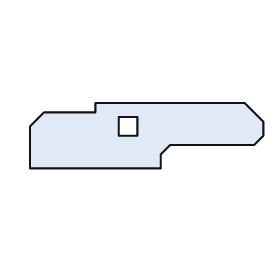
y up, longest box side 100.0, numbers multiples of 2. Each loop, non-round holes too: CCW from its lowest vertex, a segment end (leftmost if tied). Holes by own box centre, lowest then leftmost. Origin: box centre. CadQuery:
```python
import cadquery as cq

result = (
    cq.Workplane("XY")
    .moveTo(-50.0, -14.0)
    .lineTo(6.0, -14.0)
    .lineTo(6.0, -8.0)
    .lineTo(10.0, -4.0)
    .lineTo(46.0, -4.0)
    .lineTo(50.0, 0.0)
    .lineTo(50.0, 6.0)
    .lineTo(42.0, 14.0)
    .lineTo(-22.0, 14.0)
    .lineTo(-22.0, 10.0)
    .lineTo(-44.0, 10.0)
    .lineTo(-50.0, 4.0)
    .close()
    .moveTo(-12.0, 0.0)
    .lineTo(-4.0, 0.0)
    .lineTo(-4.0, 8.0)
    .lineTo(-12.0, 8.0)
    .close()
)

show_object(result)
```